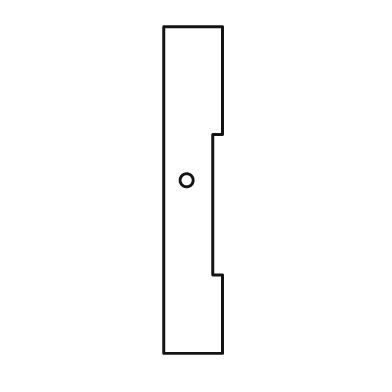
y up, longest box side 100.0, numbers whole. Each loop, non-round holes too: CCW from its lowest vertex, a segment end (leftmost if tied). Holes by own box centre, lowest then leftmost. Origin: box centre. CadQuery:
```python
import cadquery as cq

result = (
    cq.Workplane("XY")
    .moveTo(-9.0, -50.0)
    .lineTo(9.0, -50.0)
    .lineTo(9.0, -26.0)
    .lineTo(6.0, -26.0)
    .lineTo(6.0, 17.0)
    .lineTo(9.0, 17.0)
    .lineTo(9.0, 50.0)
    .lineTo(-9.0, 50.0)
    .close()
    .moveTo(-2.0, 3.0)
    .circle(2.0)
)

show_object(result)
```